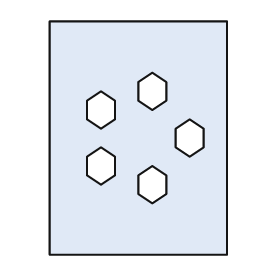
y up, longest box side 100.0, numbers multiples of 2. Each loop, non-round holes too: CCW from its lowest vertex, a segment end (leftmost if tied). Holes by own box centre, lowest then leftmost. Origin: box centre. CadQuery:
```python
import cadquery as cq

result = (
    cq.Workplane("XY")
    .moveTo(-38.0, -50.0)
    .lineTo(38.0, -50.0)
    .lineTo(38.0, 50.0)
    .lineTo(-38.0, 50.0)
    .close()
    .moveTo(6.0, -28.0)
    .lineTo(12.0, -24.0)
    .lineTo(12.0, -16.0)
    .lineTo(6.0, -12.0)
    .lineTo(0.0, -16.0)
    .lineTo(0.0, -24.0)
    .close()
    .moveTo(-16.0, -20.0)
    .lineTo(-10.0, -16.0)
    .lineTo(-10.0, -8.0)
    .lineTo(-16.0, -4.0)
    .lineTo(-22.0, -8.0)
    .lineTo(-22.0, -16.0)
    .close()
    .moveTo(22.0, -8.0)
    .lineTo(28.0, -4.0)
    .lineTo(28.0, 4.0)
    .lineTo(22.0, 8.0)
    .lineTo(16.0, 4.0)
    .lineTo(16.0, -4.0)
    .close()
    .moveTo(-16.0, 4.0)
    .lineTo(-10.0, 8.0)
    .lineTo(-10.0, 16.0)
    .lineTo(-16.0, 20.0)
    .lineTo(-22.0, 16.0)
    .lineTo(-22.0, 8.0)
    .close()
    .moveTo(6.0, 12.0)
    .lineTo(12.0, 16.0)
    .lineTo(12.0, 24.0)
    .lineTo(6.0, 28.0)
    .lineTo(0.0, 24.0)
    .lineTo(0.0, 16.0)
    .close()
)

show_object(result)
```